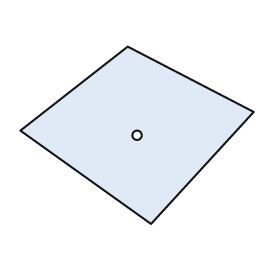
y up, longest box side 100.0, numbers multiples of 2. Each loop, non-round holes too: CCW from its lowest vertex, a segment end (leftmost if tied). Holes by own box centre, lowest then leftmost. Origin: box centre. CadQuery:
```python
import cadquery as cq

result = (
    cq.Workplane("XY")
    .moveTo(6.0, -38.0)
    .lineTo(50.0, 10.0)
    .lineTo(-4.0, 38.0)
    .lineTo(-50.0, 2.0)
    .close()
    .moveTo(0.0, 0.0)
    .circle(2.0)
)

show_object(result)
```